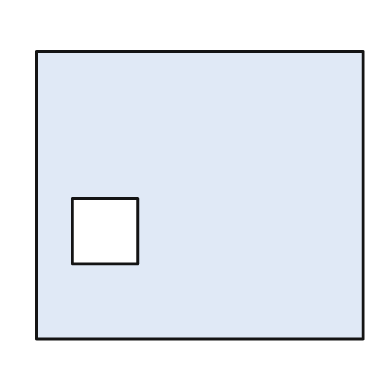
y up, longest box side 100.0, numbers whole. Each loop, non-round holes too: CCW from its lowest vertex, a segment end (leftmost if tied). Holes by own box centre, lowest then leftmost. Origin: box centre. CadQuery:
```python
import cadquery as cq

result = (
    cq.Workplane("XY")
    .moveTo(-50.0, -44.0)
    .lineTo(50.0, -44.0)
    .lineTo(50.0, 44.0)
    .lineTo(-50.0, 44.0)
    .close()
    .moveTo(-39.0, -21.0)
    .lineTo(-19.0, -21.0)
    .lineTo(-19.0, -1.0)
    .lineTo(-39.0, -1.0)
    .close()
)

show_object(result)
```